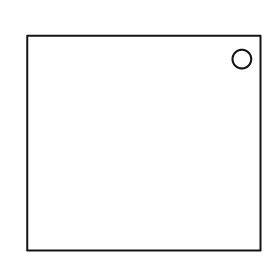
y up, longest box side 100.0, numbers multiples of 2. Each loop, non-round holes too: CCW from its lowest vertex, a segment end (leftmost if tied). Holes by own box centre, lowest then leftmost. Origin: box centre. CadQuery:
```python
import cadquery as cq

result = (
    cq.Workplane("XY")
    .moveTo(-50.0, -46.0)
    .lineTo(50.0, -46.0)
    .lineTo(50.0, 46.0)
    .lineTo(-50.0, 46.0)
    .close()
    .moveTo(42.0, 36.0)
    .circle(4.0)
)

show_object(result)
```